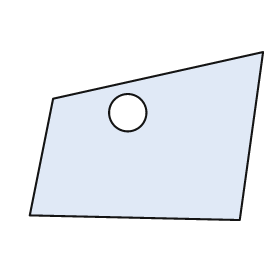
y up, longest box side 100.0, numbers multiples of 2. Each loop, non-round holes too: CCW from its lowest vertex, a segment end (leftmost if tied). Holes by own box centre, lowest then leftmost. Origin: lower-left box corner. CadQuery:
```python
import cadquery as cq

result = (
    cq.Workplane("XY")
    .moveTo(90.0, 0.0)
    .lineTo(100.0, 72.0)
    .lineTo(10.0, 52.0)
    .lineTo(0.0, 2.0)
    .close()
    .moveTo(42.0, 46.0)
    .circle(8.0)
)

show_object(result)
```